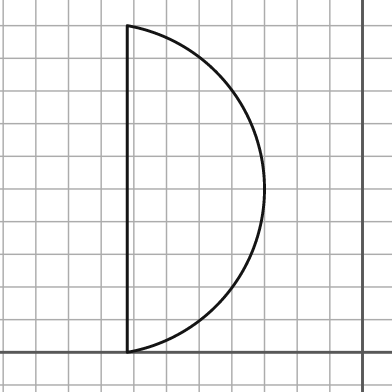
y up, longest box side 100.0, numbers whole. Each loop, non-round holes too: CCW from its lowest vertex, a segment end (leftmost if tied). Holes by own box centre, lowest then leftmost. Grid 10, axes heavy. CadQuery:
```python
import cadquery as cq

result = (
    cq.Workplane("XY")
    .moveTo(-72.0, 0.0)
    .threePointArc((-30.0, 50.0), (-72.0, 100.0))
    .close()
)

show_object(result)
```